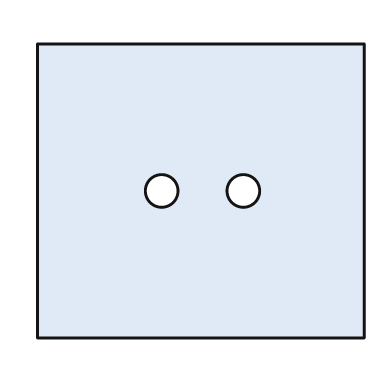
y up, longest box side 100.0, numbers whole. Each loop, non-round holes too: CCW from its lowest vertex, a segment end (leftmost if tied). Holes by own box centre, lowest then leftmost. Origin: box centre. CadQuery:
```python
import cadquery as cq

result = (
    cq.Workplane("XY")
    .moveTo(-50.0, -45.0)
    .lineTo(50.0, -45.0)
    .lineTo(50.0, 45.0)
    .lineTo(-50.0, 45.0)
    .close()
    .moveTo(-12.0, 0.0)
    .circle(5.0)
    .moveTo(13.0, 0.0)
    .circle(5.0)
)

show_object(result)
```